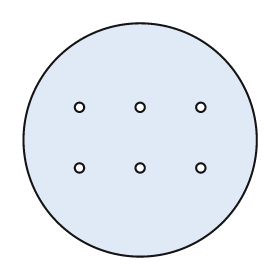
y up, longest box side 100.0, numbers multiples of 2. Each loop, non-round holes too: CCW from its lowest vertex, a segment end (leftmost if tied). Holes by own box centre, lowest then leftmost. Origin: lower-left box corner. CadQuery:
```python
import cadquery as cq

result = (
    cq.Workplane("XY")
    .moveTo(50.0, 50.0)
    .circle(50.0)
    .moveTo(24.0, 38.0)
    .circle(2.0)
    .moveTo(50.0, 38.0)
    .circle(2.0)
    .moveTo(76.0, 38.0)
    .circle(2.0)
    .moveTo(24.0, 64.0)
    .circle(2.0)
    .moveTo(50.0, 64.0)
    .circle(2.0)
    .moveTo(76.0, 64.0)
    .circle(2.0)
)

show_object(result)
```